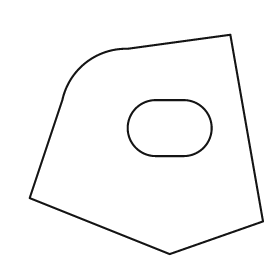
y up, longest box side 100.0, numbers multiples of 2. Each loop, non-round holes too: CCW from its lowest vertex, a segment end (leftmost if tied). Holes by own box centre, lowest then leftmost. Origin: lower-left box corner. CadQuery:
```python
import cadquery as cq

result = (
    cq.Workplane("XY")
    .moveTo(60.0, 0.0)
    .lineTo(100.0, 14.0)
    .lineTo(86.0, 94.0)
    .lineTo(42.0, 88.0)
    .threePointArc((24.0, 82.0), (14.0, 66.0))
    .lineTo(0.0, 24.0)
    .close()
    .moveTo(54.0, 42.0)
    .lineTo(66.0, 42.0)
    .threePointArc((78.0, 54.0), (66.0, 66.0))
    .lineTo(54.0, 66.0)
    .threePointArc((42.0, 54.0), (54.0, 42.0))
    .close()
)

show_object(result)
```